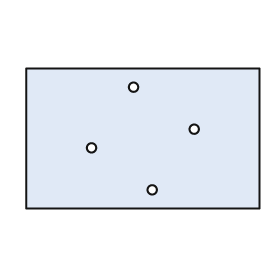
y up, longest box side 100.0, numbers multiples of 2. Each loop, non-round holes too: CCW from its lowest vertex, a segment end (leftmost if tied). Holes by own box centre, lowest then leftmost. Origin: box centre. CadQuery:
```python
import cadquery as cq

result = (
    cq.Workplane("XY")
    .moveTo(-50.0, -30.0)
    .lineTo(50.0, -30.0)
    .lineTo(50.0, 30.0)
    .lineTo(-50.0, 30.0)
    .close()
    .moveTo(4.0, -22.0)
    .circle(2.0)
    .moveTo(-22.0, -4.0)
    .circle(2.0)
    .moveTo(22.0, 4.0)
    .circle(2.0)
    .moveTo(-4.0, 22.0)
    .circle(2.0)
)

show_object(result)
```